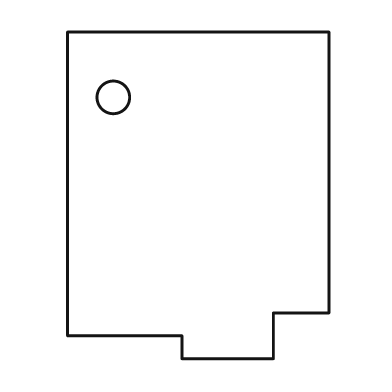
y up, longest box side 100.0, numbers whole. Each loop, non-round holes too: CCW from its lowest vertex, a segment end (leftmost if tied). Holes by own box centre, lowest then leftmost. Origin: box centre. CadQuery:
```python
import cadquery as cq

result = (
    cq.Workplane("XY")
    .moveTo(-5.0, -50.0)
    .lineTo(23.0, -50.0)
    .lineTo(23.0, -36.0)
    .lineTo(40.0, -36.0)
    .lineTo(40.0, 50.0)
    .lineTo(-40.0, 50.0)
    .lineTo(-40.0, -43.0)
    .lineTo(-5.0, -43.0)
    .close()
    .moveTo(-26.0, 30.0)
    .circle(5.0)
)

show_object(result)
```